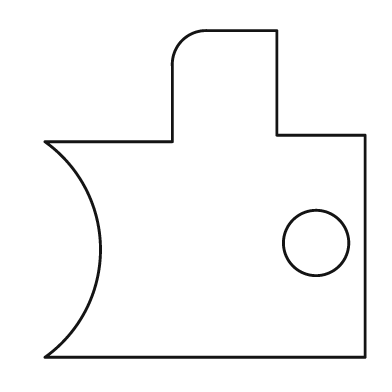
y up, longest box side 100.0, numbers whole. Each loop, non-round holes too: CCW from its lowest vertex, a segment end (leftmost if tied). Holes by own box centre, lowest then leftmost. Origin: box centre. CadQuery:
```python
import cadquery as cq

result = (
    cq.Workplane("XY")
    .moveTo(-49.0, -50.0)
    .lineTo(49.0, -50.0)
    .lineTo(49.0, 18.0)
    .lineTo(22.0, 18.0)
    .lineTo(22.0, 50.0)
    .lineTo(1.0, 50.0)
    .threePointArc((-7.0, 47.0), (-10.0, 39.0))
    .lineTo(-10.0, 16.0)
    .lineTo(-49.0, 16.0)
    .threePointArc((-32.0, -17.0), (-49.0, -50.0))
    .close()
    .moveTo(34.0, -15.0)
    .circle(10.0)
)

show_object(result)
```